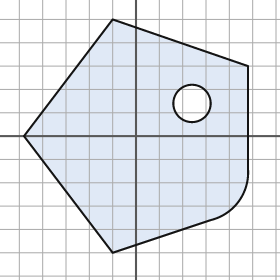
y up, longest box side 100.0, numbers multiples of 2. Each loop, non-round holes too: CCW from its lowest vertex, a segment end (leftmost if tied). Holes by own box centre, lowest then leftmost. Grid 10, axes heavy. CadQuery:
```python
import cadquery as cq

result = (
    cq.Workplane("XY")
    .moveTo(-10.0, -50.0)
    .lineTo(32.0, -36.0)
    .threePointArc((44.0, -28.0), (48.0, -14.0))
    .lineTo(48.0, 30.0)
    .lineTo(-10.0, 50.0)
    .lineTo(-48.0, 0.0)
    .close()
    .moveTo(24.0, 14.0)
    .circle(8.0)
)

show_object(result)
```